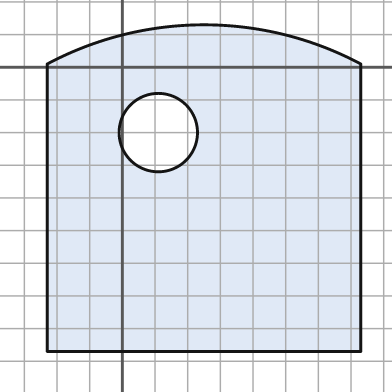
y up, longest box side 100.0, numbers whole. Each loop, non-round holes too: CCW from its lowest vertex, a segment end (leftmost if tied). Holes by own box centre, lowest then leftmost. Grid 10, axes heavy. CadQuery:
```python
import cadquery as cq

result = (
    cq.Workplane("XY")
    .moveTo(-23.0, -87.0)
    .lineTo(73.0, -87.0)
    .lineTo(73.0, 1.0)
    .threePointArc((25.0, 13.0), (-23.0, 1.0))
    .close()
    .moveTo(11.0, -20.0)
    .circle(12.0)
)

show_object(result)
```